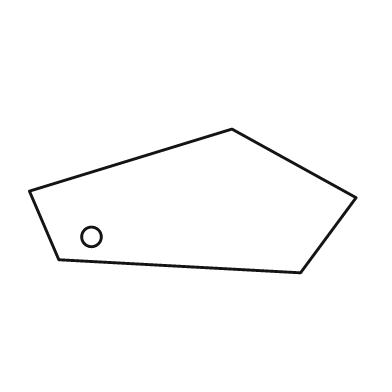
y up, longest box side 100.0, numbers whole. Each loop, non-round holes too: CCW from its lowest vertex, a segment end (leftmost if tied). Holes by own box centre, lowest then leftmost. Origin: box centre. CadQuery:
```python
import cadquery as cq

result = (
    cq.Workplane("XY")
    .moveTo(33.0, -22.0)
    .lineTo(50.0, 1.0)
    .lineTo(12.0, 22.0)
    .lineTo(-50.0, 3.0)
    .lineTo(-41.0, -18.0)
    .close()
    .moveTo(-31.0, -11.0)
    .circle(3.0)
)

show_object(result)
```